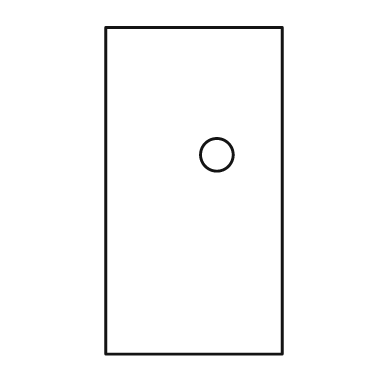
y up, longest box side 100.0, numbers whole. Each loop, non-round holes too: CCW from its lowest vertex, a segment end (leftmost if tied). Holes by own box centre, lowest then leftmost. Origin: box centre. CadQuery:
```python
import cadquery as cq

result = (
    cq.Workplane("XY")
    .moveTo(-27.0, -50.0)
    .lineTo(27.0, -50.0)
    .lineTo(27.0, 50.0)
    .lineTo(-27.0, 50.0)
    .close()
    .moveTo(7.0, 11.0)
    .circle(5.0)
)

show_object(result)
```